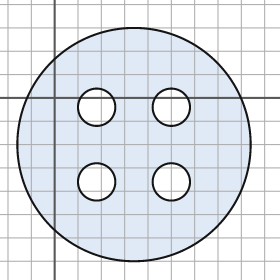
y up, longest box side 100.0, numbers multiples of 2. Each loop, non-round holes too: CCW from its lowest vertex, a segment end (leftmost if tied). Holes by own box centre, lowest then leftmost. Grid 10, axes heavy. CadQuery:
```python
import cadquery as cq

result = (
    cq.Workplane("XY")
    .moveTo(34.0, -20.0)
    .circle(50.0)
    .moveTo(18.0, -36.0)
    .circle(8.0)
    .moveTo(50.0, -36.0)
    .circle(8.0)
    .moveTo(18.0, -4.0)
    .circle(8.0)
    .moveTo(50.0, -4.0)
    .circle(8.0)
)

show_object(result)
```